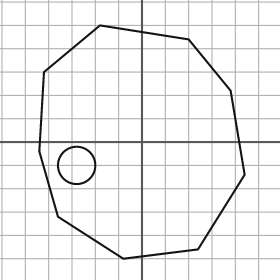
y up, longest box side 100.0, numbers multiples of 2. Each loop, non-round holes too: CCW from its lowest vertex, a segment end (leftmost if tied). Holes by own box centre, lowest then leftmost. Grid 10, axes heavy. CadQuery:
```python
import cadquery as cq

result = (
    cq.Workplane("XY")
    .moveTo(-8.0, -50.0)
    .lineTo(24.0, -46.0)
    .lineTo(44.0, -14.0)
    .lineTo(38.0, 22.0)
    .lineTo(20.0, 44.0)
    .lineTo(-18.0, 50.0)
    .lineTo(-42.0, 30.0)
    .lineTo(-44.0, -4.0)
    .lineTo(-36.0, -32.0)
    .close()
    .moveTo(-28.0, -10.0)
    .circle(8.0)
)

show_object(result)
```